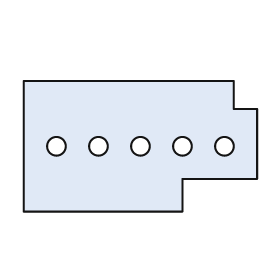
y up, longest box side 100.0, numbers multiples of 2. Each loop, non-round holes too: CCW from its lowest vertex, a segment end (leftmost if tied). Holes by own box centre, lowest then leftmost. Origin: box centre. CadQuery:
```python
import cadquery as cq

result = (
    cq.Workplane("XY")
    .moveTo(-50.0, -28.0)
    .lineTo(18.0, -28.0)
    .lineTo(18.0, -14.0)
    .lineTo(50.0, -14.0)
    .lineTo(50.0, 16.0)
    .lineTo(40.0, 16.0)
    .lineTo(40.0, 28.0)
    .lineTo(-50.0, 28.0)
    .close()
    .moveTo(-36.0, 0.0)
    .circle(4.0)
    .moveTo(-18.0, 0.0)
    .circle(4.0)
    .moveTo(0.0, 0.0)
    .circle(4.0)
    .moveTo(18.0, 0.0)
    .circle(4.0)
    .moveTo(36.0, 0.0)
    .circle(4.0)
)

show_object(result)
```